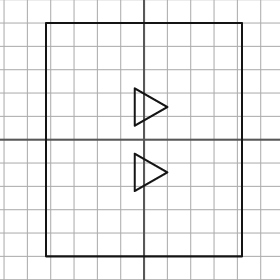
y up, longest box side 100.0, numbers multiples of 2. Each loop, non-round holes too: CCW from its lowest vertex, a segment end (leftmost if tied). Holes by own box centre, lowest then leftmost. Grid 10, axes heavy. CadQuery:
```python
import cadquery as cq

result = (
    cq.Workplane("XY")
    .moveTo(-42.0, -50.0)
    .lineTo(42.0, -50.0)
    .lineTo(42.0, 50.0)
    .lineTo(-42.0, 50.0)
    .close()
    .moveTo(-4.0, -22.0)
    .lineTo(10.0, -14.0)
    .lineTo(-4.0, -6.0)
    .close()
    .moveTo(-4.0, 6.0)
    .lineTo(10.0, 14.0)
    .lineTo(-4.0, 22.0)
    .close()
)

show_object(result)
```